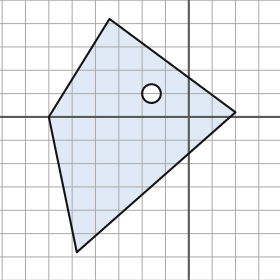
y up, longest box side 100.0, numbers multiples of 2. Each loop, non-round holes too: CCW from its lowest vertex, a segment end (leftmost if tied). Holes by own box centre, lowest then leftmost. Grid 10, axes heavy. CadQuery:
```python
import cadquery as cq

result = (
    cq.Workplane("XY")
    .moveTo(-48.0, -58.0)
    .lineTo(20.0, 2.0)
    .lineTo(-34.0, 42.0)
    .lineTo(-60.0, 0.0)
    .close()
    .moveTo(-16.0, 10.0)
    .circle(4.0)
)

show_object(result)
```